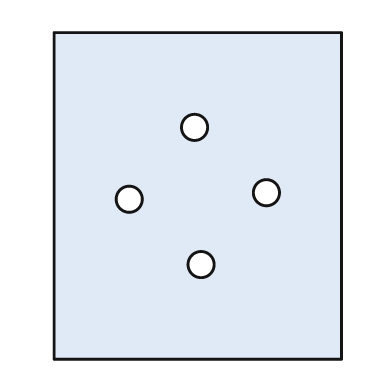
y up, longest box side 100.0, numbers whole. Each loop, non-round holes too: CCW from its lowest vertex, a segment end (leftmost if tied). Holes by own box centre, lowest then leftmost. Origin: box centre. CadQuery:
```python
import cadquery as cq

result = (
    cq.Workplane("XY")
    .moveTo(-44.0, -50.0)
    .lineTo(44.0, -50.0)
    .lineTo(44.0, 50.0)
    .lineTo(-44.0, 50.0)
    .close()
    .moveTo(1.0, -21.0)
    .circle(4.0)
    .moveTo(-21.0, -1.0)
    .circle(4.0)
    .moveTo(21.0, 1.0)
    .circle(4.0)
    .moveTo(-1.0, 21.0)
    .circle(4.0)
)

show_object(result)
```